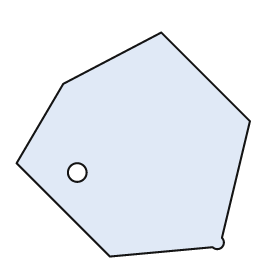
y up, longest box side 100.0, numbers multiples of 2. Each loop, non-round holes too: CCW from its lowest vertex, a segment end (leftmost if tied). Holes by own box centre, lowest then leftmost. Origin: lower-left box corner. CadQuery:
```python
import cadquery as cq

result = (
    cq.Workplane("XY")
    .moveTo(40.0, 0.0)
    .lineTo(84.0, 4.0)
    .threePointArc((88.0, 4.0), (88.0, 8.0))
    .lineTo(100.0, 58.0)
    .lineTo(62.0, 96.0)
    .lineTo(20.0, 74.0)
    .lineTo(0.0, 40.0)
    .close()
    .moveTo(26.0, 36.0)
    .circle(4.0)
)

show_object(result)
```